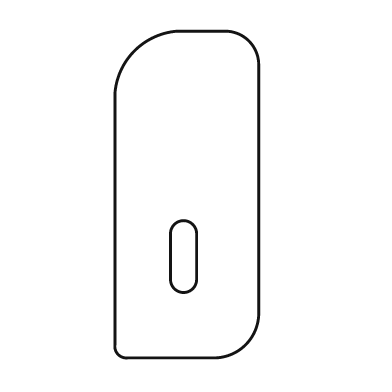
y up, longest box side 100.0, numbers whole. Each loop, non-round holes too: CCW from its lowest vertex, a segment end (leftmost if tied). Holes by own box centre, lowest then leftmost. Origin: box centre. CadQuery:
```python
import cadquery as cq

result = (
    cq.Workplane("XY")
    .moveTo(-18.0, -50.0)
    .lineTo(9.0, -50.0)
    .threePointArc((18.0, -46.0), (22.0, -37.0))
    .lineTo(22.0, 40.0)
    .threePointArc((19.0, 47.0), (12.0, 50.0))
    .lineTo(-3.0, 50.0)
    .threePointArc((-16.0, 44.0), (-22.0, 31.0))
    .lineTo(-22.0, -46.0)
    .threePointArc((-21.0, -49.0), (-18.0, -50.0))
    .close()
    .moveTo(-5.0, -26.0)
    .threePointArc((-1.0, -30.0), (3.0, -26.0))
    .lineTo(3.0, -12.0)
    .threePointArc((-1.0, -8.0), (-5.0, -12.0))
    .close()
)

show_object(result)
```